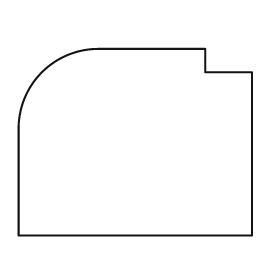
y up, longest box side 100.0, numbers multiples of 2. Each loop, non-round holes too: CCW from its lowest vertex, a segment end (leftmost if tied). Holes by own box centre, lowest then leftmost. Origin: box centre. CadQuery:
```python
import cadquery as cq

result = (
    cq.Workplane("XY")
    .moveTo(-50.0, -40.0)
    .lineTo(50.0, -40.0)
    .lineTo(50.0, 30.0)
    .lineTo(30.0, 30.0)
    .lineTo(30.0, 40.0)
    .lineTo(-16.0, 40.0)
    .threePointArc((-40.0, 30.0), (-50.0, 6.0))
    .close()
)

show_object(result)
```